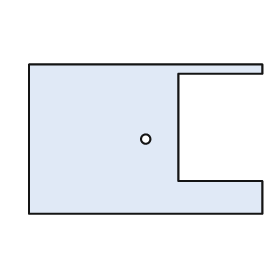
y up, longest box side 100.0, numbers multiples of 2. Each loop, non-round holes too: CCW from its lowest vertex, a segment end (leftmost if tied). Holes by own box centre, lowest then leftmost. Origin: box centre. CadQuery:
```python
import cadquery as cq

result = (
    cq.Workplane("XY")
    .moveTo(-50.0, -32.0)
    .lineTo(50.0, -32.0)
    .lineTo(50.0, -18.0)
    .lineTo(14.0, -18.0)
    .lineTo(14.0, 28.0)
    .lineTo(50.0, 28.0)
    .lineTo(50.0, 32.0)
    .lineTo(-50.0, 32.0)
    .close()
    .moveTo(0.0, 0.0)
    .circle(2.0)
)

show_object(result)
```